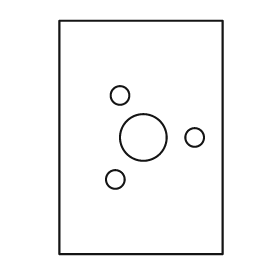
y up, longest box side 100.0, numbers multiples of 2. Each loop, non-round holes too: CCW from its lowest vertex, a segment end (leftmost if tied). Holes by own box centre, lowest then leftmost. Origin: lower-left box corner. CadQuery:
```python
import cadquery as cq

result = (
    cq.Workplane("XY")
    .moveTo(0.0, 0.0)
    .lineTo(70.0, 0.0)
    .lineTo(70.0, 100.0)
    .lineTo(0.0, 100.0)
    .close()
    .moveTo(24.0, 32.0)
    .circle(4.0)
    .moveTo(36.0, 50.0)
    .circle(10.0)
    .moveTo(58.0, 50.0)
    .circle(4.0)
    .moveTo(26.0, 68.0)
    .circle(4.0)
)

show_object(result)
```